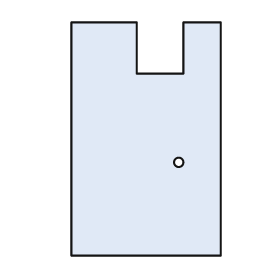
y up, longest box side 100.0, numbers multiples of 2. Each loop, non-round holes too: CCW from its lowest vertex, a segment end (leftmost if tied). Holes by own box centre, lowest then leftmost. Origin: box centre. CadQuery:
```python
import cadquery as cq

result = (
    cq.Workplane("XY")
    .moveTo(-32.0, -50.0)
    .lineTo(32.0, -50.0)
    .lineTo(32.0, 50.0)
    .lineTo(16.0, 50.0)
    .lineTo(16.0, 28.0)
    .lineTo(-4.0, 28.0)
    .lineTo(-4.0, 50.0)
    .lineTo(-32.0, 50.0)
    .close()
    .moveTo(14.0, -10.0)
    .circle(2.0)
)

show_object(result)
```